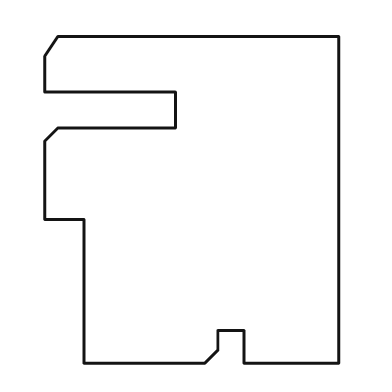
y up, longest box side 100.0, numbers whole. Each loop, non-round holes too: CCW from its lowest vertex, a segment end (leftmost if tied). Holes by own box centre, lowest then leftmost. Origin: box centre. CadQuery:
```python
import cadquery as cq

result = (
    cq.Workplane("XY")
    .moveTo(-33.0, -50.0)
    .lineTo(4.0, -50.0)
    .lineTo(8.0, -46.0)
    .lineTo(8.0, -40.0)
    .lineTo(16.0, -40.0)
    .lineTo(16.0, -50.0)
    .lineTo(45.0, -50.0)
    .lineTo(45.0, 50.0)
    .lineTo(-41.0, 50.0)
    .lineTo(-45.0, 44.0)
    .lineTo(-45.0, 33.0)
    .lineTo(-5.0, 33.0)
    .lineTo(-5.0, 22.0)
    .lineTo(-41.0, 22.0)
    .lineTo(-45.0, 18.0)
    .lineTo(-45.0, -6.0)
    .lineTo(-33.0, -6.0)
    .close()
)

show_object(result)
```